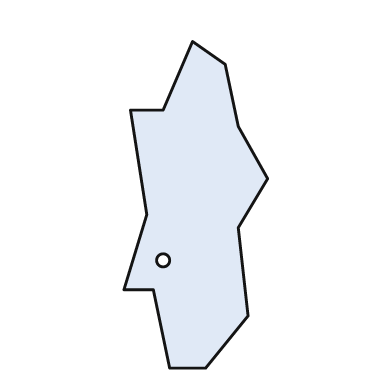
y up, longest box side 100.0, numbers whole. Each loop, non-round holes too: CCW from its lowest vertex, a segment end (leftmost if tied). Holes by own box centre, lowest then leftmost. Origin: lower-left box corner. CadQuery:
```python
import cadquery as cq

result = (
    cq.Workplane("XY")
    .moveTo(14.0, 0.0)
    .lineTo(25.0, 0.0)
    .lineTo(38.0, 16.0)
    .lineTo(35.0, 43.0)
    .lineTo(44.0, 58.0)
    .lineTo(35.0, 74.0)
    .lineTo(31.0, 93.0)
    .lineTo(21.0, 100.0)
    .lineTo(12.0, 79.0)
    .lineTo(2.0, 79.0)
    .lineTo(7.0, 47.0)
    .lineTo(0.0, 24.0)
    .lineTo(9.0, 24.0)
    .close()
    .moveTo(12.0, 33.0)
    .circle(2.0)
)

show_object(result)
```